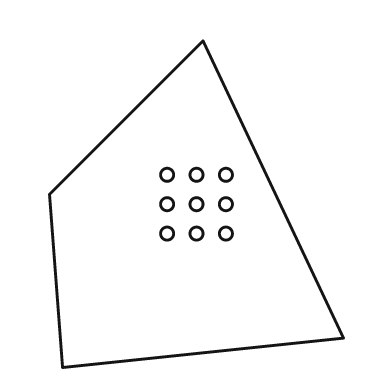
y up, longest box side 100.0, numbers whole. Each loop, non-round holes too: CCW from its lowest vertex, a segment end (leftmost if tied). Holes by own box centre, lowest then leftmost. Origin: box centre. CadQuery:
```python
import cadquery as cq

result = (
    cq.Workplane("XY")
    .moveTo(-41.0, -50.0)
    .lineTo(45.0, -41.0)
    .lineTo(2.0, 50.0)
    .lineTo(-45.0, 3.0)
    .close()
    .moveTo(-9.0, -9.0)
    .circle(2.0)
    .moveTo(0.0, -9.0)
    .circle(2.0)
    .moveTo(9.0, -9.0)
    .circle(2.0)
    .moveTo(-9.0, 0.0)
    .circle(2.0)
    .moveTo(0.0, 0.0)
    .circle(2.0)
    .moveTo(9.0, 0.0)
    .circle(2.0)
    .moveTo(-9.0, 9.0)
    .circle(2.0)
    .moveTo(0.0, 9.0)
    .circle(2.0)
    .moveTo(9.0, 9.0)
    .circle(2.0)
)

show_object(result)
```